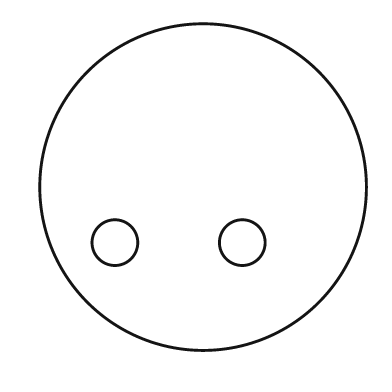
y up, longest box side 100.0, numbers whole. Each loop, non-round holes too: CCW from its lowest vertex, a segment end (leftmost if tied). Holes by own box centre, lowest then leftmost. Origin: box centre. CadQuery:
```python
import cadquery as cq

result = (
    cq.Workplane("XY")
    .moveTo(0.0, 0.0)
    .circle(50.0)
    .moveTo(-27.0, -17.0)
    .circle(7.0)
    .moveTo(12.0, -17.0)
    .circle(7.0)
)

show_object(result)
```